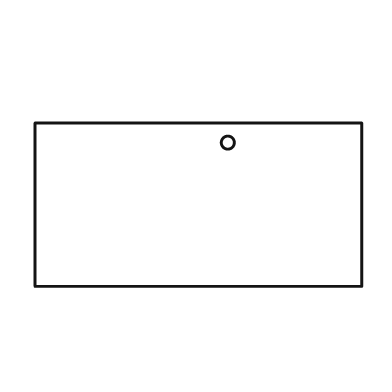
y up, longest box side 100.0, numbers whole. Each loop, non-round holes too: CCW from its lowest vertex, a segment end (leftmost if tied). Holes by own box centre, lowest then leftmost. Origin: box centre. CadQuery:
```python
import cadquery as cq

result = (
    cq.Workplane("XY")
    .moveTo(-50.0, -25.0)
    .lineTo(50.0, -25.0)
    .lineTo(50.0, 25.0)
    .lineTo(-50.0, 25.0)
    .close()
    .moveTo(9.0, 19.0)
    .circle(2.0)
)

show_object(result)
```